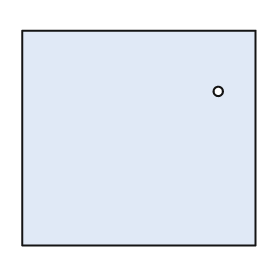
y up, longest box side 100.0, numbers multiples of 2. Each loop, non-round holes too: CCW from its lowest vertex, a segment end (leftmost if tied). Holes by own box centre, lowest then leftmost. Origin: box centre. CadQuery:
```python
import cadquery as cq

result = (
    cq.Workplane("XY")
    .moveTo(-50.0, -46.0)
    .lineTo(50.0, -46.0)
    .lineTo(50.0, 46.0)
    .lineTo(-50.0, 46.0)
    .close()
    .moveTo(34.0, 20.0)
    .circle(2.0)
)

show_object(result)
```